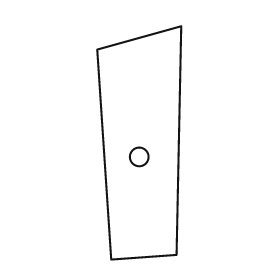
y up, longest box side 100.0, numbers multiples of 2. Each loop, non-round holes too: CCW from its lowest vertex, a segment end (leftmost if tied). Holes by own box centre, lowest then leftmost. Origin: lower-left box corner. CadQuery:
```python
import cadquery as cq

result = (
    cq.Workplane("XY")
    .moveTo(6.0, 0.0)
    .lineTo(34.0, 2.0)
    .lineTo(36.0, 100.0)
    .lineTo(0.0, 90.0)
    .close()
    .moveTo(18.0, 44.0)
    .circle(4.0)
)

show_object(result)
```